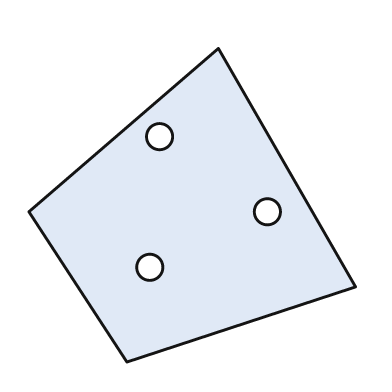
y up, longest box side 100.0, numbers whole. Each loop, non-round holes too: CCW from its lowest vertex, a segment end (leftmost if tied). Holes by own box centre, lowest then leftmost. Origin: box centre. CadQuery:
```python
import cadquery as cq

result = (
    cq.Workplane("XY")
    .moveTo(-20.0, -48.0)
    .lineTo(50.0, -25.0)
    .lineTo(8.0, 48.0)
    .lineTo(-50.0, -2.0)
    .close()
    .moveTo(-13.0, -19.0)
    .circle(4.0)
    .moveTo(23.0, -2.0)
    .circle(4.0)
    .moveTo(-10.0, 21.0)
    .circle(4.0)
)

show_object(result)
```